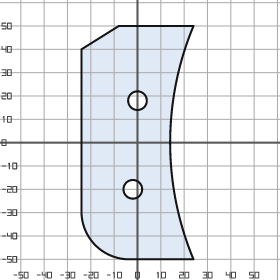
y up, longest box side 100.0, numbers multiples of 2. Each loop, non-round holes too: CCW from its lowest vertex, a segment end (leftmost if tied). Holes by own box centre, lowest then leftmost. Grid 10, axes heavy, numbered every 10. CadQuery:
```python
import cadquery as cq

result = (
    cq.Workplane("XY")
    .moveTo(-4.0, -50.0)
    .lineTo(24.0, -50.0)
    .threePointArc((14.0, 0.0), (24.0, 50.0))
    .lineTo(-8.0, 50.0)
    .lineTo(-24.0, 40.0)
    .lineTo(-24.0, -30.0)
    .threePointArc((-18.0, -44.0), (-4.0, -50.0))
    .close()
    .moveTo(-2.0, -20.0)
    .circle(4.0)
    .moveTo(0.0, 18.0)
    .circle(4.0)
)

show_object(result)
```